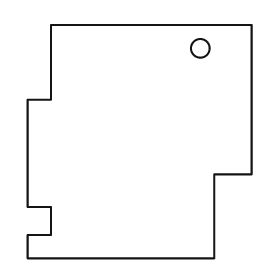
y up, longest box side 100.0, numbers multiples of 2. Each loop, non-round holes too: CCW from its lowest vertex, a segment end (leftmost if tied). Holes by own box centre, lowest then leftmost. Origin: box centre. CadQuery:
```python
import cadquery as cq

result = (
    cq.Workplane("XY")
    .moveTo(-48.0, -50.0)
    .lineTo(32.0, -50.0)
    .lineTo(32.0, -14.0)
    .lineTo(48.0, -14.0)
    .lineTo(48.0, 50.0)
    .lineTo(-38.0, 50.0)
    .lineTo(-38.0, 18.0)
    .lineTo(-48.0, 18.0)
    .lineTo(-48.0, -28.0)
    .lineTo(-38.0, -28.0)
    .lineTo(-38.0, -40.0)
    .lineTo(-48.0, -40.0)
    .close()
    .moveTo(26.0, 40.0)
    .circle(4.0)
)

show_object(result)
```